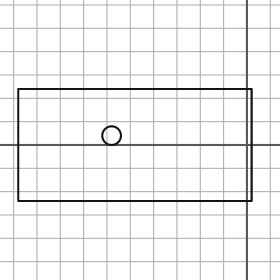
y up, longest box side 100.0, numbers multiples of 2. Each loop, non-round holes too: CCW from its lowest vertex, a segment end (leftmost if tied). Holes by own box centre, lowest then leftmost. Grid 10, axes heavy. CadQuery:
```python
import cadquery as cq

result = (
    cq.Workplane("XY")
    .moveTo(-98.0, -24.0)
    .lineTo(2.0, -24.0)
    .lineTo(2.0, 24.0)
    .lineTo(-98.0, 24.0)
    .close()
    .moveTo(-58.0, 4.0)
    .circle(4.0)
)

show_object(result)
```